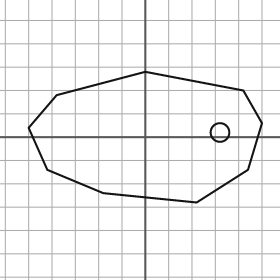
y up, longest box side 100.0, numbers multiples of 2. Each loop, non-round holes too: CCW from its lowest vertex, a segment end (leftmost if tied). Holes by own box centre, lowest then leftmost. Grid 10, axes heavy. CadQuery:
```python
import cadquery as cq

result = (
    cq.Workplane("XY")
    .moveTo(22.0, -28.0)
    .lineTo(44.0, -14.0)
    .lineTo(50.0, 6.0)
    .lineTo(42.0, 20.0)
    .lineTo(0.0, 28.0)
    .lineTo(-38.0, 18.0)
    .lineTo(-50.0, 4.0)
    .lineTo(-42.0, -14.0)
    .lineTo(-18.0, -24.0)
    .close()
    .moveTo(32.0, 2.0)
    .circle(4.0)
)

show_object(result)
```